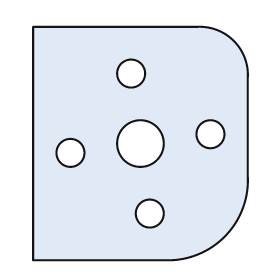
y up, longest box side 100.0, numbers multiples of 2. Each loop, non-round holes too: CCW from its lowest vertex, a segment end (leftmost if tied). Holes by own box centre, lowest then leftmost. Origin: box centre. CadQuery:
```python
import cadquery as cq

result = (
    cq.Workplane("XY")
    .moveTo(-46.0, -50.0)
    .lineTo(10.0, -50.0)
    .threePointArc((36.0, -40.0), (46.0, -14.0))
    .lineTo(46.0, 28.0)
    .threePointArc((40.0, 44.0), (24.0, 50.0))
    .lineTo(-46.0, 50.0)
    .close()
    .moveTo(4.0, -30.0)
    .circle(6.0)
    .moveTo(-30.0, -4.0)
    .circle(6.0)
    .moveTo(0.0, 0.0)
    .circle(10.0)
    .moveTo(30.0, 4.0)
    .circle(6.0)
    .moveTo(-4.0, 30.0)
    .circle(6.0)
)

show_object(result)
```